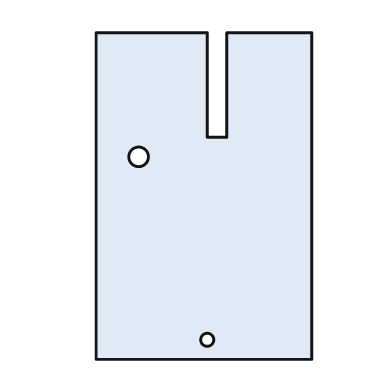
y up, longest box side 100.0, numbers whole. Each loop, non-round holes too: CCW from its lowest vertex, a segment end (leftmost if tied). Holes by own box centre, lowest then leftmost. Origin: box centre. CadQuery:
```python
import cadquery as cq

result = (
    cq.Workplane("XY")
    .moveTo(-33.0, -50.0)
    .lineTo(33.0, -50.0)
    .lineTo(33.0, 50.0)
    .lineTo(7.0, 50.0)
    .lineTo(7.0, 18.0)
    .lineTo(1.0, 18.0)
    .lineTo(1.0, 50.0)
    .lineTo(-33.0, 50.0)
    .close()
    .moveTo(1.0, -44.0)
    .circle(2.0)
    .moveTo(-20.0, 12.0)
    .circle(3.0)
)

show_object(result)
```